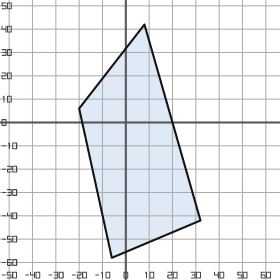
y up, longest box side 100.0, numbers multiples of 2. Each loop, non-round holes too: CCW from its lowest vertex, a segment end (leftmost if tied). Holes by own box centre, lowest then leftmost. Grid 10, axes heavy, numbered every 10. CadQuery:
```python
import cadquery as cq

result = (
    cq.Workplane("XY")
    .moveTo(-6.0, -58.0)
    .lineTo(32.0, -42.0)
    .lineTo(8.0, 42.0)
    .lineTo(-20.0, 6.0)
    .close()
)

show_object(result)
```